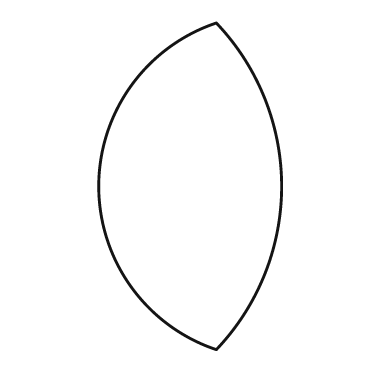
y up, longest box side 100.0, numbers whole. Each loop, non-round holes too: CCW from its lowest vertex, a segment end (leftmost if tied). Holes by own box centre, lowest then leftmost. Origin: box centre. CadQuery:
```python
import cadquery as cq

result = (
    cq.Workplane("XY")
    .moveTo(8.0, -50.0)
    .threePointArc((28.0, 0.0), (8.0, 50.0))
    .threePointArc((-28.0, 0.0), (8.0, -50.0))
    .close()
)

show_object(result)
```